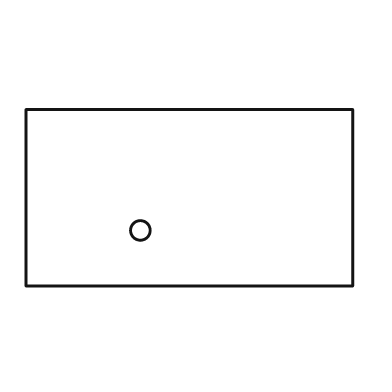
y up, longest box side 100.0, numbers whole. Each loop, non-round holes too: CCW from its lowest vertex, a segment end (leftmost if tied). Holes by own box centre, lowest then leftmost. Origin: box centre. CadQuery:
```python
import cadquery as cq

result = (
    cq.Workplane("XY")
    .moveTo(-50.0, -27.0)
    .lineTo(50.0, -27.0)
    .lineTo(50.0, 27.0)
    .lineTo(-50.0, 27.0)
    .close()
    .moveTo(-15.0, -10.0)
    .circle(3.0)
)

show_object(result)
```